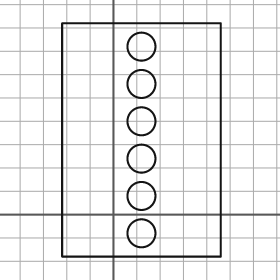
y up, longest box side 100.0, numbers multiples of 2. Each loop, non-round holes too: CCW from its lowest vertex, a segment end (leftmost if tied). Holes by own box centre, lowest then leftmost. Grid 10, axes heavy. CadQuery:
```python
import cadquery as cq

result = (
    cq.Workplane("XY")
    .moveTo(-22.0, -18.0)
    .lineTo(46.0, -18.0)
    .lineTo(46.0, 82.0)
    .lineTo(-22.0, 82.0)
    .close()
    .moveTo(12.0, -8.0)
    .circle(6.0)
    .moveTo(12.0, 8.0)
    .circle(6.0)
    .moveTo(12.0, 24.0)
    .circle(6.0)
    .moveTo(12.0, 40.0)
    .circle(6.0)
    .moveTo(12.0, 56.0)
    .circle(6.0)
    .moveTo(12.0, 72.0)
    .circle(6.0)
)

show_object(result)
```